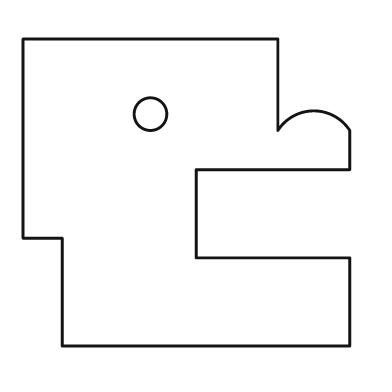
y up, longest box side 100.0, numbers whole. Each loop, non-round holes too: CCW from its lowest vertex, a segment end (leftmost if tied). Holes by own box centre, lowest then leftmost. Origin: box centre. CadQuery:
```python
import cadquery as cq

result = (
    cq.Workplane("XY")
    .moveTo(-38.0, -47.0)
    .lineTo(50.0, -47.0)
    .lineTo(50.0, -20.0)
    .lineTo(3.0, -20.0)
    .lineTo(3.0, 7.0)
    .lineTo(50.0, 7.0)
    .lineTo(50.0, 19.0)
    .threePointArc((39.0, 25.0), (28.0, 19.0))
    .lineTo(28.0, 47.0)
    .lineTo(-50.0, 47.0)
    .lineTo(-50.0, -14.0)
    .lineTo(-38.0, -14.0)
    .close()
    .moveTo(-11.0, 24.0)
    .circle(5.0)
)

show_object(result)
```